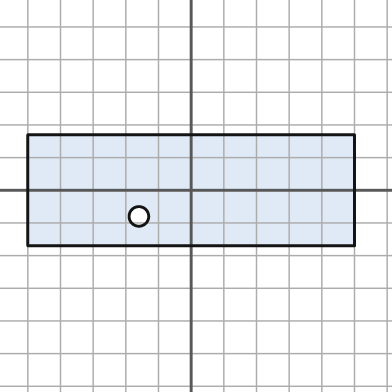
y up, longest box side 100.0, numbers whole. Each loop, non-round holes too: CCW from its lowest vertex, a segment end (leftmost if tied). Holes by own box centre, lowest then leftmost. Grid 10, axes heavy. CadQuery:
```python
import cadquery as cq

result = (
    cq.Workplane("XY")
    .moveTo(-50.0, -17.0)
    .lineTo(50.0, -17.0)
    .lineTo(50.0, 17.0)
    .lineTo(-50.0, 17.0)
    .close()
    .moveTo(-16.0, -8.0)
    .circle(3.0)
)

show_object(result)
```